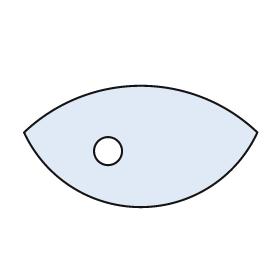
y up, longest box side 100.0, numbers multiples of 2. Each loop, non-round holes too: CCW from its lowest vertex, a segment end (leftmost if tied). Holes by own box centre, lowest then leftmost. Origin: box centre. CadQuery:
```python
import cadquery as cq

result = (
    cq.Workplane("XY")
    .moveTo(-50.0, 6.0)
    .threePointArc((0.0, -26.0), (50.0, 6.0))
    .threePointArc((0.0, 26.0), (-50.0, 6.0))
    .close()
    .moveTo(-14.0, -2.0)
    .circle(6.0)
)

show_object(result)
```